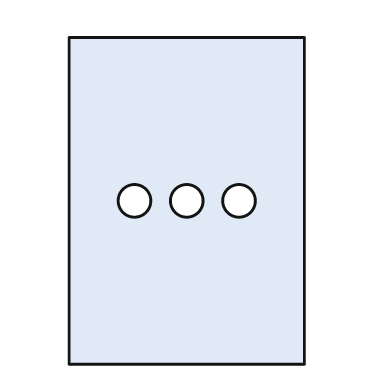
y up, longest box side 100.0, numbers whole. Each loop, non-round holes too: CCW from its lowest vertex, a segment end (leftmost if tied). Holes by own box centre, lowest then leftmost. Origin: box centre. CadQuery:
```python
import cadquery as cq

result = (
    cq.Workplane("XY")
    .moveTo(-36.0, -50.0)
    .lineTo(36.0, -50.0)
    .lineTo(36.0, 50.0)
    .lineTo(-36.0, 50.0)
    .close()
    .moveTo(-16.0, 0.0)
    .circle(5.0)
    .moveTo(0.0, 0.0)
    .circle(5.0)
    .moveTo(16.0, 0.0)
    .circle(5.0)
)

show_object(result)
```